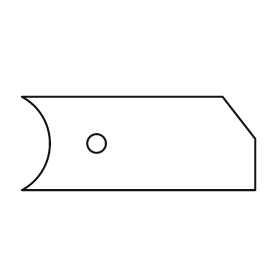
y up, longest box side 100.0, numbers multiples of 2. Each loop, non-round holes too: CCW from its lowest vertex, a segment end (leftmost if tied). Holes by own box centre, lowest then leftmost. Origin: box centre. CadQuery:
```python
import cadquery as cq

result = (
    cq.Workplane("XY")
    .moveTo(-50.0, -20.0)
    .lineTo(50.0, -20.0)
    .lineTo(50.0, 2.0)
    .lineTo(36.0, 20.0)
    .lineTo(-50.0, 20.0)
    .threePointArc((-38.0, 0.0), (-50.0, -20.0))
    .close()
    .moveTo(-18.0, 0.0)
    .circle(4.0)
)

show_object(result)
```